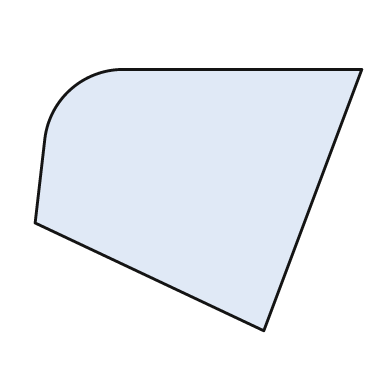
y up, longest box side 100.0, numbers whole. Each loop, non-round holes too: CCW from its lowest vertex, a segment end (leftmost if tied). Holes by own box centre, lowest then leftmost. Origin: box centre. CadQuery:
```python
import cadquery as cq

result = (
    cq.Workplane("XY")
    .moveTo(20.0, -40.0)
    .lineTo(50.0, 40.0)
    .lineTo(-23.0, 40.0)
    .threePointArc((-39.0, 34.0), (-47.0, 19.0))
    .lineTo(-50.0, -7.0)
    .close()
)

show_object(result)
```